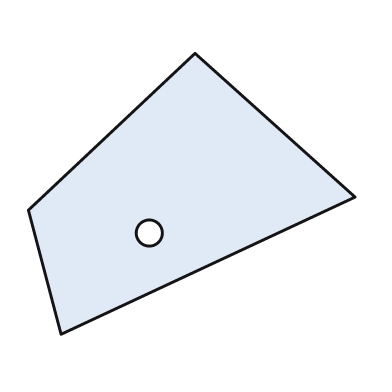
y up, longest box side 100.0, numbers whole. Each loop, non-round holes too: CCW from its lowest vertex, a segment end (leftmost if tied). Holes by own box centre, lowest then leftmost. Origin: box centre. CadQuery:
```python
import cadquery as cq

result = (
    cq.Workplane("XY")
    .moveTo(-40.0, -43.0)
    .lineTo(50.0, -1.0)
    .lineTo(1.0, 43.0)
    .lineTo(-50.0, -5.0)
    .close()
    .moveTo(-13.0, -12.0)
    .circle(4.0)
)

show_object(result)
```